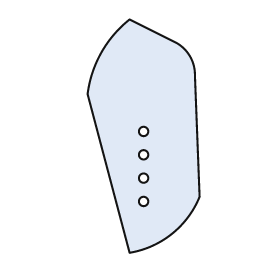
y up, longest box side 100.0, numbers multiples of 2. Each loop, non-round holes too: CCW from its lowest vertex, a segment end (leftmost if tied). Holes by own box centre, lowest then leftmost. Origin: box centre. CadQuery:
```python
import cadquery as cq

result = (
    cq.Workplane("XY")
    .moveTo(-6.0, -50.0)
    .threePointArc((12.0, -42.0), (24.0, -26.0))
    .lineTo(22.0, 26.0)
    .threePointArc((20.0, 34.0), (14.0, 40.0))
    .lineTo(-6.0, 50.0)
    .threePointArc((-18.0, 36.0), (-24.0, 18.0))
    .close()
    .moveTo(0.0, -28.0)
    .circle(2.0)
    .moveTo(0.0, -18.0)
    .circle(2.0)
    .moveTo(0.0, -8.0)
    .circle(2.0)
    .moveTo(0.0, 2.0)
    .circle(2.0)
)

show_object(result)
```